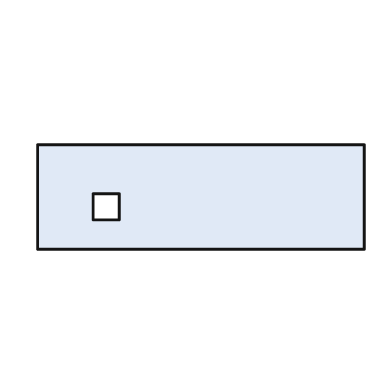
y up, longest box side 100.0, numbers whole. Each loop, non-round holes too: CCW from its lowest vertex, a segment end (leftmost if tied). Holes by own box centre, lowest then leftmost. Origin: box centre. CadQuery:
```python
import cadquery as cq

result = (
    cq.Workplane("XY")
    .moveTo(-50.0, -16.0)
    .lineTo(50.0, -16.0)
    .lineTo(50.0, 16.0)
    .lineTo(-50.0, 16.0)
    .close()
    .moveTo(-33.0, -7.0)
    .lineTo(-25.0, -7.0)
    .lineTo(-25.0, 1.0)
    .lineTo(-33.0, 1.0)
    .close()
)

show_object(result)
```